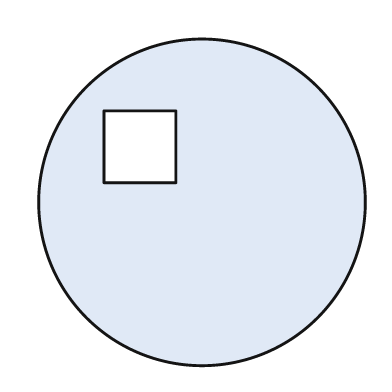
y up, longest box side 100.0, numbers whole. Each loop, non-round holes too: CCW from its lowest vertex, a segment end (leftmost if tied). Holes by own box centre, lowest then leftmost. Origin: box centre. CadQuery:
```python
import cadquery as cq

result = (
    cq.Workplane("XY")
    .moveTo(0.0, 0.0)
    .circle(50.0)
    .moveTo(-30.0, 6.0)
    .lineTo(-8.0, 6.0)
    .lineTo(-8.0, 28.0)
    .lineTo(-30.0, 28.0)
    .close()
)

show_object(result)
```